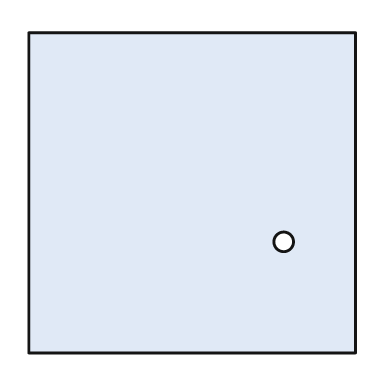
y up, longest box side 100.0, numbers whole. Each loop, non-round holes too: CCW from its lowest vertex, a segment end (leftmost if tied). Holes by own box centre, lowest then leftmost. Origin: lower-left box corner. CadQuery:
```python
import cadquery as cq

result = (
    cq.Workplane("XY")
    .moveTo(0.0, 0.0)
    .lineTo(100.0, 0.0)
    .lineTo(100.0, 98.0)
    .lineTo(0.0, 98.0)
    .close()
    .moveTo(78.0, 34.0)
    .circle(3.0)
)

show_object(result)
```